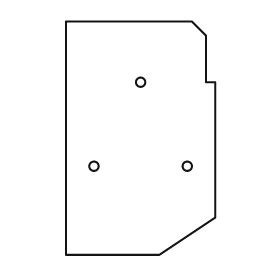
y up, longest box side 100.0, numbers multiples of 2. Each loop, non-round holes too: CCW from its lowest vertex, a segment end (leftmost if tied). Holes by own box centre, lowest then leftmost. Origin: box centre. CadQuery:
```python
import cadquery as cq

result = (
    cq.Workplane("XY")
    .moveTo(-32.0, -50.0)
    .lineTo(8.0, -50.0)
    .lineTo(32.0, -34.0)
    .lineTo(32.0, 24.0)
    .lineTo(28.0, 24.0)
    .lineTo(28.0, 44.0)
    .lineTo(22.0, 50.0)
    .lineTo(-32.0, 50.0)
    .close()
    .moveTo(-20.0, -12.0)
    .circle(2.0)
    .moveTo(20.0, -12.0)
    .circle(2.0)
    .moveTo(0.0, 24.0)
    .circle(2.0)
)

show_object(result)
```